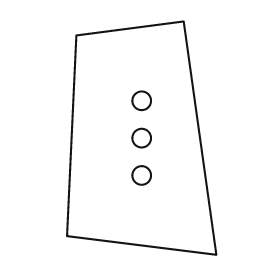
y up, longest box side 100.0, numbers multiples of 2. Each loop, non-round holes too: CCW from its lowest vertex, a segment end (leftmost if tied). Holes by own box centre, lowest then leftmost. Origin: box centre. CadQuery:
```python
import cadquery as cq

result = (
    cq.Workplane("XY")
    .moveTo(32.0, -50.0)
    .lineTo(18.0, 50.0)
    .lineTo(-28.0, 44.0)
    .lineTo(-32.0, -42.0)
    .close()
    .moveTo(0.0, -16.0)
    .circle(4.0)
    .moveTo(0.0, 0.0)
    .circle(4.0)
    .moveTo(0.0, 16.0)
    .circle(4.0)
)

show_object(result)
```